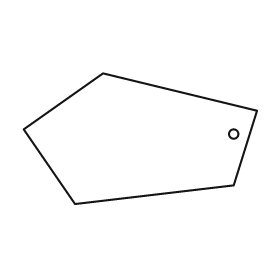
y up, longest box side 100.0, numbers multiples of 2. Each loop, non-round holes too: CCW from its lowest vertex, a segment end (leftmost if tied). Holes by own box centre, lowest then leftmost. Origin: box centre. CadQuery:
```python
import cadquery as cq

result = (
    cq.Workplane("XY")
    .moveTo(-28.0, -28.0)
    .lineTo(40.0, -20.0)
    .lineTo(50.0, 12.0)
    .lineTo(-16.0, 28.0)
    .lineTo(-50.0, 4.0)
    .close()
    .moveTo(40.0, 2.0)
    .circle(2.0)
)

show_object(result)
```